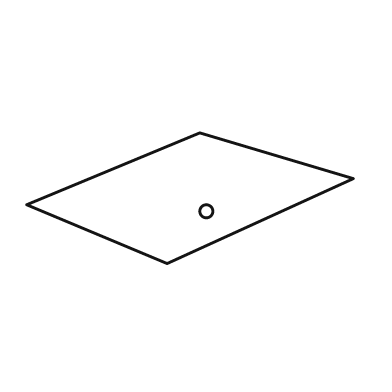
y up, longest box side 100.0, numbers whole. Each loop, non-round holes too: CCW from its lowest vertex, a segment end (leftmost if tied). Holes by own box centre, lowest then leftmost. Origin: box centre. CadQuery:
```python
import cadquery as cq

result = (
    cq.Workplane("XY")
    .moveTo(-7.0, -20.0)
    .lineTo(50.0, 6.0)
    .lineTo(3.0, 20.0)
    .lineTo(-50.0, -2.0)
    .close()
    .moveTo(5.0, -4.0)
    .circle(2.0)
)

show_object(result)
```